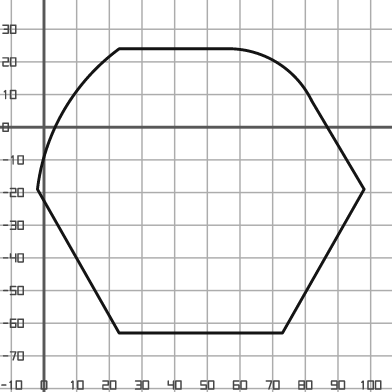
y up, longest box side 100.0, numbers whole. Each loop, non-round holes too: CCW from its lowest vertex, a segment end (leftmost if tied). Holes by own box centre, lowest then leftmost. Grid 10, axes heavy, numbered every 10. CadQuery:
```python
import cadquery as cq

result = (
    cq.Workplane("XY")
    .moveTo(23.0, -63.0)
    .lineTo(73.0, -63.0)
    .lineTo(98.0, -19.0)
    .lineTo(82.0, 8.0)
    .threePointArc((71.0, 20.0), (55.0, 24.0))
    .lineTo(23.0, 24.0)
    .threePointArc((6.0, 5.0), (-2.0, -19.0))
    .close()
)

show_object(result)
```